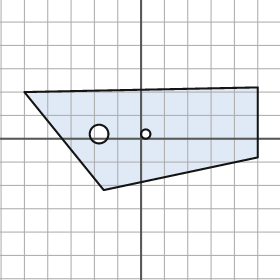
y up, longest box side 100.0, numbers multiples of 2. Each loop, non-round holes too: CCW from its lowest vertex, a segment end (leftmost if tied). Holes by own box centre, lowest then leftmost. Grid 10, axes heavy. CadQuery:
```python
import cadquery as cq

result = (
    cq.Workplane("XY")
    .moveTo(-16.0, -22.0)
    .lineTo(50.0, -8.0)
    .lineTo(50.0, 22.0)
    .lineTo(-50.0, 20.0)
    .close()
    .moveTo(-18.0, 2.0)
    .circle(4.0)
    .moveTo(2.0, 2.0)
    .circle(2.0)
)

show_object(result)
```